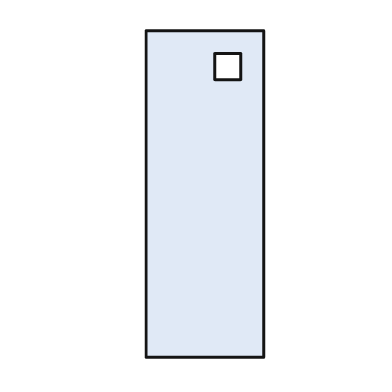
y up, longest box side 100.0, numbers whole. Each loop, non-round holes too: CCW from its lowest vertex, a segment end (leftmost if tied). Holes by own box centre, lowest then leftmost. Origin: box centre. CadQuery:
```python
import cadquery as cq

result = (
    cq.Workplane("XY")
    .moveTo(-18.0, -50.0)
    .lineTo(18.0, -50.0)
    .lineTo(18.0, 50.0)
    .lineTo(-18.0, 50.0)
    .close()
    .moveTo(3.0, 35.0)
    .lineTo(11.0, 35.0)
    .lineTo(11.0, 43.0)
    .lineTo(3.0, 43.0)
    .close()
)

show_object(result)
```